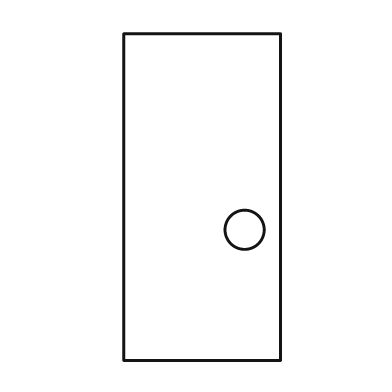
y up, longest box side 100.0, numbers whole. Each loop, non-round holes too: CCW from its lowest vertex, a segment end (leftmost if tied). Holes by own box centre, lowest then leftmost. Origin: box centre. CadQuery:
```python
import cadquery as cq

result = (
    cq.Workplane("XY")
    .moveTo(-24.0, -50.0)
    .lineTo(24.0, -50.0)
    .lineTo(24.0, 50.0)
    .lineTo(-24.0, 50.0)
    .close()
    .moveTo(13.0, -10.0)
    .circle(6.0)
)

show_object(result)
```